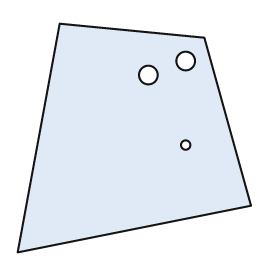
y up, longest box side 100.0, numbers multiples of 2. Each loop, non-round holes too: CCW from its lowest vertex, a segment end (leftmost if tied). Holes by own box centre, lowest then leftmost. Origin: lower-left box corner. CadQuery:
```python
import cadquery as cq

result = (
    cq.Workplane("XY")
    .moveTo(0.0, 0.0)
    .lineTo(100.0, 20.0)
    .lineTo(80.0, 92.0)
    .lineTo(18.0, 98.0)
    .close()
    .moveTo(72.0, 46.0)
    .circle(2.0)
    .moveTo(56.0, 76.0)
    .circle(4.0)
    .moveTo(72.0, 82.0)
    .circle(4.0)
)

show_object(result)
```